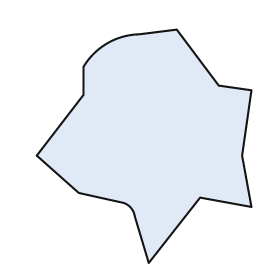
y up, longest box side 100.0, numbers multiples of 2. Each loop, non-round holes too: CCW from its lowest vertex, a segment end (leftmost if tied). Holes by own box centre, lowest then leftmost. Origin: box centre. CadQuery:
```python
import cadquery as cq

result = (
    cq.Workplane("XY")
    .moveTo(2.0, -50.0)
    .lineTo(24.0, -22.0)
    .lineTo(46.0, -26.0)
    .lineTo(42.0, -4.0)
    .lineTo(46.0, 24.0)
    .lineTo(32.0, 26.0)
    .lineTo(14.0, 50.0)
    .lineTo(-2.0, 48.0)
    .threePointArc((-16.0, 44.0), (-26.0, 34.0))
    .lineTo(-26.0, 22.0)
    .lineTo(-46.0, -4.0)
    .lineTo(-28.0, -20.0)
    .lineTo(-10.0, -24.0)
    .threePointArc((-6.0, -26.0), (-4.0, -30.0))
    .close()
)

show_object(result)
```